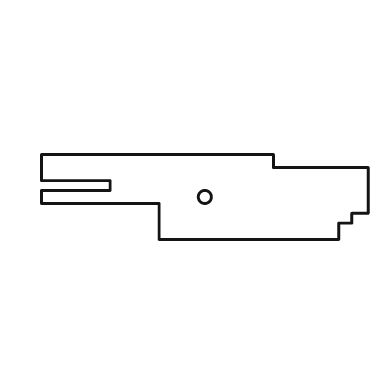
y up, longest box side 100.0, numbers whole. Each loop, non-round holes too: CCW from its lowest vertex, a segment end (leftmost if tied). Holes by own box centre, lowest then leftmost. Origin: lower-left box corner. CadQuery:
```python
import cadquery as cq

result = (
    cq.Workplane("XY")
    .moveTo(36.0, 0.0)
    .lineTo(91.0, 0.0)
    .lineTo(91.0, 5.0)
    .lineTo(95.0, 5.0)
    .lineTo(95.0, 8.0)
    .lineTo(100.0, 8.0)
    .lineTo(100.0, 22.0)
    .lineTo(71.0, 22.0)
    .lineTo(71.0, 26.0)
    .lineTo(0.0, 26.0)
    .lineTo(0.0, 18.0)
    .lineTo(21.0, 18.0)
    .lineTo(21.0, 15.0)
    .lineTo(0.0, 15.0)
    .lineTo(0.0, 11.0)
    .lineTo(36.0, 11.0)
    .close()
    .moveTo(50.0, 13.0)
    .circle(2.0)
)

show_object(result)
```